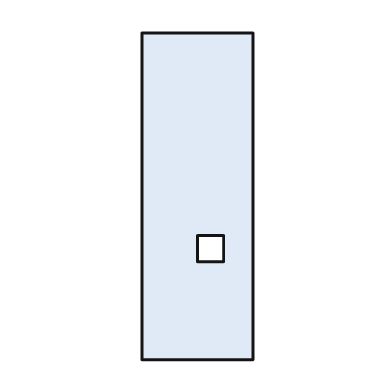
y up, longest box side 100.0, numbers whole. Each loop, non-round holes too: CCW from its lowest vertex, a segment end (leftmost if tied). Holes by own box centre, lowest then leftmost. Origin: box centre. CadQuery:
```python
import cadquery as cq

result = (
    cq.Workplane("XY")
    .moveTo(-17.0, -50.0)
    .lineTo(17.0, -50.0)
    .lineTo(17.0, 50.0)
    .lineTo(-17.0, 50.0)
    .close()
    .moveTo(0.0, -20.0)
    .lineTo(8.0, -20.0)
    .lineTo(8.0, -12.0)
    .lineTo(0.0, -12.0)
    .close()
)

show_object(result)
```